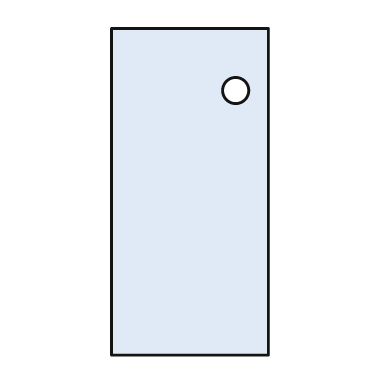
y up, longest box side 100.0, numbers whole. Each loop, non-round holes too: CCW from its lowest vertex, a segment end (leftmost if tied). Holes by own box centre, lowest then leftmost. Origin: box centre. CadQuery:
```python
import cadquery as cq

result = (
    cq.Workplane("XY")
    .moveTo(-24.0, -50.0)
    .lineTo(24.0, -50.0)
    .lineTo(24.0, 50.0)
    .lineTo(-24.0, 50.0)
    .close()
    .moveTo(14.0, 31.0)
    .circle(4.0)
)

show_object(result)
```